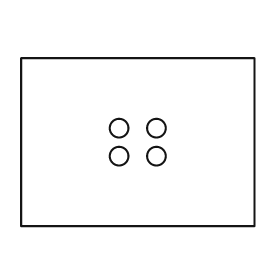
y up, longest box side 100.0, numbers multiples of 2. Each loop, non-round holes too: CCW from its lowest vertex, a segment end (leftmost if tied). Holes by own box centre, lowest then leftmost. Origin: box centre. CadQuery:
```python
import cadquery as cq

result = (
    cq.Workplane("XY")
    .moveTo(-50.0, -36.0)
    .lineTo(50.0, -36.0)
    .lineTo(50.0, 36.0)
    .lineTo(-50.0, 36.0)
    .close()
    .moveTo(-8.0, -6.0)
    .circle(4.0)
    .moveTo(8.0, -6.0)
    .circle(4.0)
    .moveTo(-8.0, 6.0)
    .circle(4.0)
    .moveTo(8.0, 6.0)
    .circle(4.0)
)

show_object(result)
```